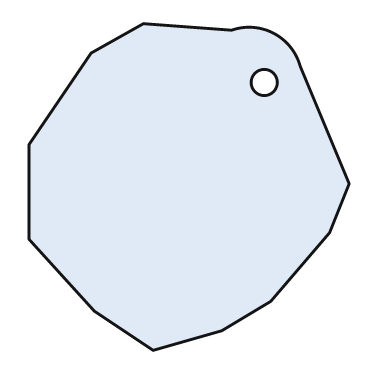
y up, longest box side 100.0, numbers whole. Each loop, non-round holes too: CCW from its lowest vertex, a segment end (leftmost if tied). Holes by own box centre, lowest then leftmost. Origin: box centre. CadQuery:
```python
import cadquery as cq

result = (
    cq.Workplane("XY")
    .moveTo(-11.0, -50.0)
    .lineTo(10.0, -44.0)
    .lineTo(25.0, -35.0)
    .lineTo(43.0, -14.0)
    .lineTo(49.0, 1.0)
    .lineTo(34.0, 37.0)
    .threePointArc((26.0, 47.0), (13.0, 48.0))
    .lineTo(-14.0, 50.0)
    .lineTo(-30.0, 41.0)
    .lineTo(-49.0, 13.0)
    .lineTo(-49.0, -16.0)
    .lineTo(-29.0, -38.0)
    .close()
    .moveTo(23.0, 32.0)
    .circle(4.0)
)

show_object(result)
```